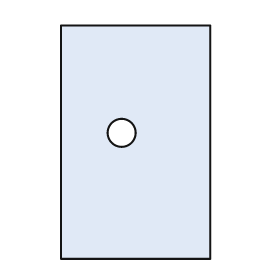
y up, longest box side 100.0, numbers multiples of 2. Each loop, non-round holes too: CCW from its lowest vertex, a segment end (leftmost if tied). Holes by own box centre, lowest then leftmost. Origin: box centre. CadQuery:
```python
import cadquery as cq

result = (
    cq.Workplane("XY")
    .moveTo(-32.0, -50.0)
    .lineTo(32.0, -50.0)
    .lineTo(32.0, 50.0)
    .lineTo(-32.0, 50.0)
    .close()
    .moveTo(-6.0, 4.0)
    .circle(6.0)
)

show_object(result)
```